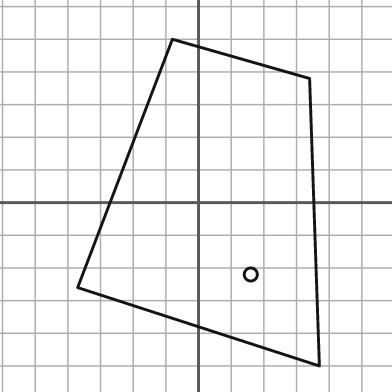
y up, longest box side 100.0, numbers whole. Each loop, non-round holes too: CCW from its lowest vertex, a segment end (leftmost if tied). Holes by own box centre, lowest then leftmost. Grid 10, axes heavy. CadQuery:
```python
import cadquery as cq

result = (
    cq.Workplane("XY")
    .moveTo(37.0, -50.0)
    .lineTo(34.0, 38.0)
    .lineTo(-8.0, 50.0)
    .lineTo(-37.0, -26.0)
    .close()
    .moveTo(16.0, -22.0)
    .circle(2.0)
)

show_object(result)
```